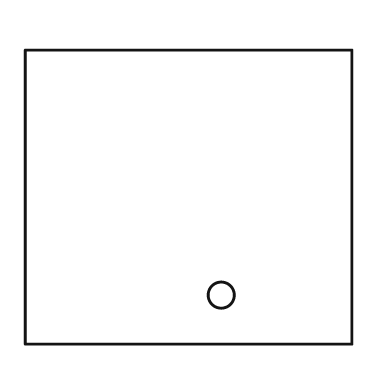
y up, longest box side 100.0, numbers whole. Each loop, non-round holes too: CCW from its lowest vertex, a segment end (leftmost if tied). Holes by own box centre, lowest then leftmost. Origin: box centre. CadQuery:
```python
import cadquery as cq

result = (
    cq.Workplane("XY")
    .moveTo(-50.0, -45.0)
    .lineTo(50.0, -45.0)
    .lineTo(50.0, 45.0)
    .lineTo(-50.0, 45.0)
    .close()
    .moveTo(10.0, -30.0)
    .circle(4.0)
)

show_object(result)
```